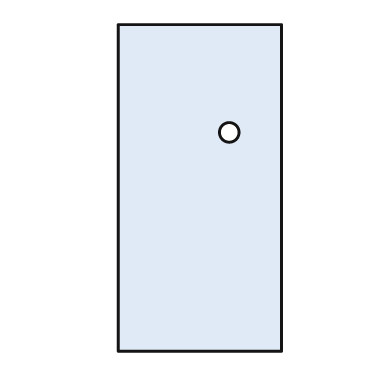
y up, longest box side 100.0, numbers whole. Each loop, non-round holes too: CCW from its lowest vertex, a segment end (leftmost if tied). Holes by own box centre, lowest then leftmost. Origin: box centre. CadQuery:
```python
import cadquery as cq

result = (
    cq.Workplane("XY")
    .moveTo(-25.0, -50.0)
    .lineTo(25.0, -50.0)
    .lineTo(25.0, 50.0)
    .lineTo(-25.0, 50.0)
    .close()
    .moveTo(9.0, 17.0)
    .circle(3.0)
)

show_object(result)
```